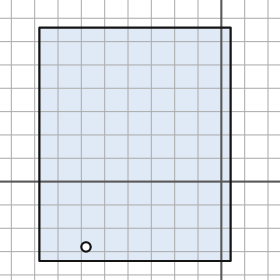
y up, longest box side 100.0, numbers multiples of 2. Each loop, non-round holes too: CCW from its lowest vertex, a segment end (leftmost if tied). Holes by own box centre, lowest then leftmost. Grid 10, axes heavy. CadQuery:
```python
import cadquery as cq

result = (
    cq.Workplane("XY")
    .moveTo(-78.0, -34.0)
    .lineTo(4.0, -34.0)
    .lineTo(4.0, 66.0)
    .lineTo(-78.0, 66.0)
    .close()
    .moveTo(-58.0, -28.0)
    .circle(2.0)
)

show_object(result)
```